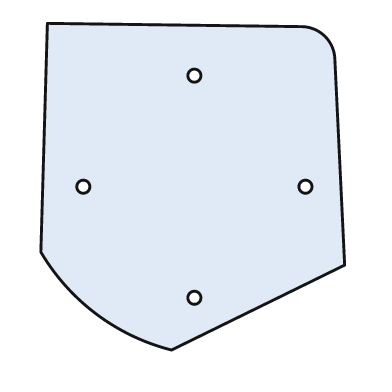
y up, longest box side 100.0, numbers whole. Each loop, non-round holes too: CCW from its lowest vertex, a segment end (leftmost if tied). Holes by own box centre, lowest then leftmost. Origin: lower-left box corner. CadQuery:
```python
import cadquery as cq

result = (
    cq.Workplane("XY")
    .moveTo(40.0, 0.0)
    .lineTo(93.0, 26.0)
    .lineTo(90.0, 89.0)
    .threePointArc((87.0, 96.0), (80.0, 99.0))
    .lineTo(2.0, 100.0)
    .lineTo(0.0, 30.0)
    .threePointArc((17.0, 11.0), (40.0, 0.0))
    .close()
    .moveTo(47.0, 16.0)
    .circle(2.0)
    .moveTo(13.0, 50.0)
    .circle(2.0)
    .moveTo(81.0, 50.0)
    .circle(2.0)
    .moveTo(47.0, 84.0)
    .circle(2.0)
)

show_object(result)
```